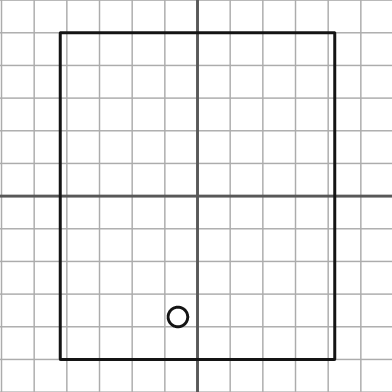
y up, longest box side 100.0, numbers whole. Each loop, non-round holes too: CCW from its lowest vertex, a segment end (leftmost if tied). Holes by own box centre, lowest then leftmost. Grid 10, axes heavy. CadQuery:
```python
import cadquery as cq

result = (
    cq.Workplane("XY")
    .moveTo(-42.0, -50.0)
    .lineTo(42.0, -50.0)
    .lineTo(42.0, 50.0)
    .lineTo(-42.0, 50.0)
    .close()
    .moveTo(-6.0, -37.0)
    .circle(3.0)
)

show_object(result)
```